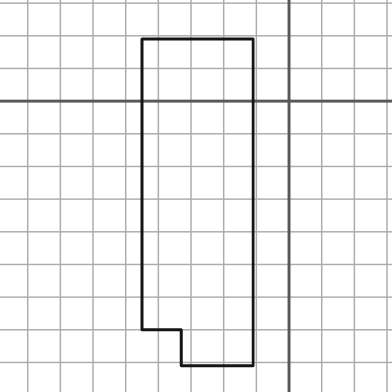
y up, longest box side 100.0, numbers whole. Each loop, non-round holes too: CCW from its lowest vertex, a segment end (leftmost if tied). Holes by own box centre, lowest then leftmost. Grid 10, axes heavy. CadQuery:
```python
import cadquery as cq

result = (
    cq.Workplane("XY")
    .moveTo(-33.0, -81.0)
    .lineTo(-11.0, -81.0)
    .lineTo(-11.0, 19.0)
    .lineTo(-45.0, 19.0)
    .lineTo(-45.0, -70.0)
    .lineTo(-33.0, -70.0)
    .close()
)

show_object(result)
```